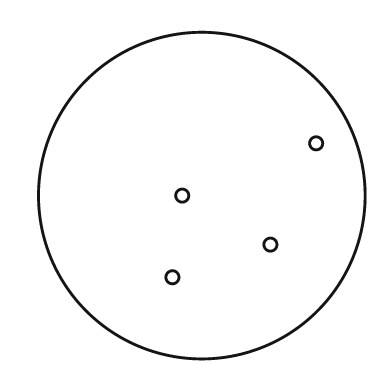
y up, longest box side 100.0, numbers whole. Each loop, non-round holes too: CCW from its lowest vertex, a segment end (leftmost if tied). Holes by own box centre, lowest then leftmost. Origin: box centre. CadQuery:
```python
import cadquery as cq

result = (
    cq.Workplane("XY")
    .moveTo(0.0, 0.0)
    .circle(50.0)
    .moveTo(-9.0, -25.0)
    .circle(2.0)
    .moveTo(21.0, -15.0)
    .circle(2.0)
    .moveTo(-6.0, 0.0)
    .circle(2.0)
    .moveTo(35.0, 16.0)
    .circle(2.0)
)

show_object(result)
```